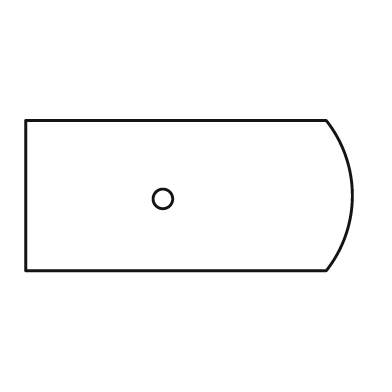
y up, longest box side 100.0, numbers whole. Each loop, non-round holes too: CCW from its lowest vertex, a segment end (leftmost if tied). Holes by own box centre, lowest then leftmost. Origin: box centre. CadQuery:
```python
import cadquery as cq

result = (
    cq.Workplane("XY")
    .moveTo(-50.0, -23.0)
    .lineTo(42.0, -23.0)
    .threePointArc((50.0, 0.0), (42.0, 23.0))
    .lineTo(-50.0, 23.0)
    .close()
    .moveTo(-8.0, -1.0)
    .circle(3.0)
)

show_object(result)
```